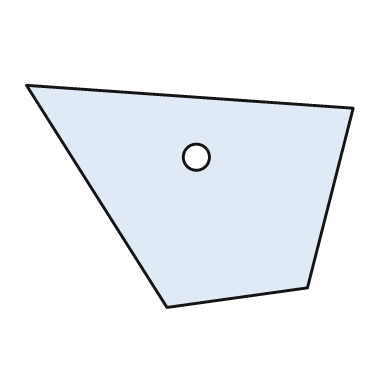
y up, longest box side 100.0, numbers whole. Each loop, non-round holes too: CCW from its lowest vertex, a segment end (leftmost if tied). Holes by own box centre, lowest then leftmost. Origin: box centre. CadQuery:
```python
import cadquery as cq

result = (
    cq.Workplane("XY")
    .moveTo(-7.0, -34.0)
    .lineTo(36.0, -28.0)
    .lineTo(50.0, 27.0)
    .lineTo(-50.0, 34.0)
    .close()
    .moveTo(2.0, 12.0)
    .circle(4.0)
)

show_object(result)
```